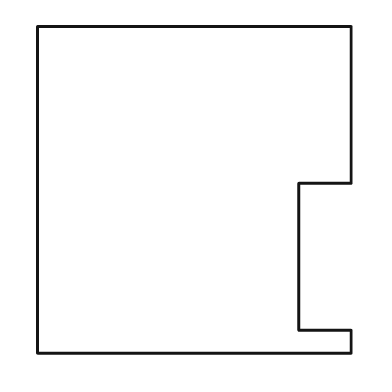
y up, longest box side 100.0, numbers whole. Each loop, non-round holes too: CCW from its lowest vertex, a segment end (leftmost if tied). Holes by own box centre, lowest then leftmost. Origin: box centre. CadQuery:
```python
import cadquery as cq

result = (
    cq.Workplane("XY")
    .moveTo(-48.0, -50.0)
    .lineTo(48.0, -50.0)
    .lineTo(48.0, -43.0)
    .lineTo(32.0, -43.0)
    .lineTo(32.0, 2.0)
    .lineTo(48.0, 2.0)
    .lineTo(48.0, 50.0)
    .lineTo(-48.0, 50.0)
    .close()
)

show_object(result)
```